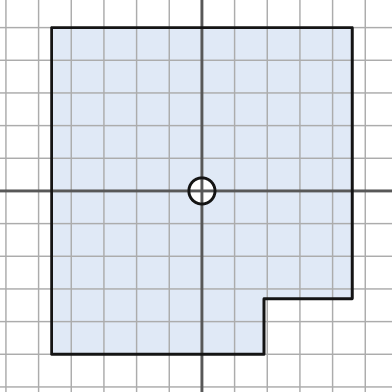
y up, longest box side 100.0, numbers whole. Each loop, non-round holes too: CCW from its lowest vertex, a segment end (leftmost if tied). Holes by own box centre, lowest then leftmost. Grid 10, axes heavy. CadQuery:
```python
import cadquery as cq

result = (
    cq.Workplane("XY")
    .moveTo(-46.0, -50.0)
    .lineTo(19.0, -50.0)
    .lineTo(19.0, -33.0)
    .lineTo(46.0, -33.0)
    .lineTo(46.0, 50.0)
    .lineTo(-46.0, 50.0)
    .close()
    .moveTo(0.0, 0.0)
    .circle(4.0)
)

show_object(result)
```